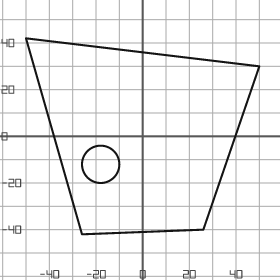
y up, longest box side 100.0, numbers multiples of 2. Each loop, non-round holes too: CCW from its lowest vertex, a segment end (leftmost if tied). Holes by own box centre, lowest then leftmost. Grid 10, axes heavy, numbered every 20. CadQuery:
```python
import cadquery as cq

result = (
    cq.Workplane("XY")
    .moveTo(-26.0, -42.0)
    .lineTo(26.0, -40.0)
    .lineTo(50.0, 30.0)
    .lineTo(-50.0, 42.0)
    .close()
    .moveTo(-18.0, -12.0)
    .circle(8.0)
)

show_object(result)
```